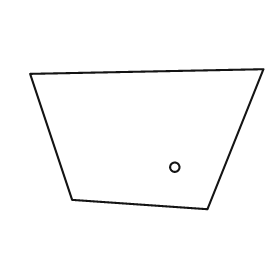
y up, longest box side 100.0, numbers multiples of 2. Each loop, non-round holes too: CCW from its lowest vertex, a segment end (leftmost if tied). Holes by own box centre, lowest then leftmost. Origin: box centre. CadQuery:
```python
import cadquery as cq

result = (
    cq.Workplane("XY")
    .moveTo(26.0, -30.0)
    .lineTo(50.0, 30.0)
    .lineTo(-50.0, 28.0)
    .lineTo(-32.0, -26.0)
    .close()
    .moveTo(12.0, -12.0)
    .circle(2.0)
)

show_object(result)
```